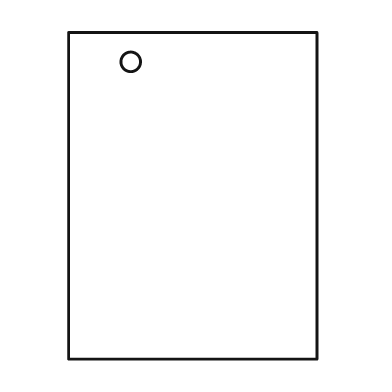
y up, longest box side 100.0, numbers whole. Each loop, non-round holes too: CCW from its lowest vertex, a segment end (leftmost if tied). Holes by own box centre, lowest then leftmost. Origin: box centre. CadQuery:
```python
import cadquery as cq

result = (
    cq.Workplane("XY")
    .moveTo(-38.0, -50.0)
    .lineTo(38.0, -50.0)
    .lineTo(38.0, 50.0)
    .lineTo(-38.0, 50.0)
    .close()
    .moveTo(-19.0, 41.0)
    .circle(3.0)
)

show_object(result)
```